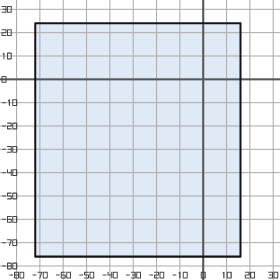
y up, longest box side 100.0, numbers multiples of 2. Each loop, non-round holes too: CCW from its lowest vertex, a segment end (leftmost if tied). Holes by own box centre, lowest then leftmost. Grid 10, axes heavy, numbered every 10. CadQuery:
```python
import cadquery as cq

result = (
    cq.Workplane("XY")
    .moveTo(-72.0, -76.0)
    .lineTo(16.0, -76.0)
    .lineTo(16.0, 24.0)
    .lineTo(-72.0, 24.0)
    .close()
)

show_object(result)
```